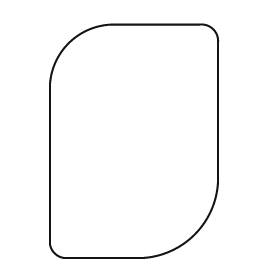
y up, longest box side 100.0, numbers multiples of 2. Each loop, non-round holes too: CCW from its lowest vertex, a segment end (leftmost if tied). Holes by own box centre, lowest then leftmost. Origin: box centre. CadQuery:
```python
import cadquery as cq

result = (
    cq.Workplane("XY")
    .moveTo(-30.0, -50.0)
    .lineTo(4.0, -50.0)
    .threePointArc((26.0, -40.0), (36.0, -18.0))
    .lineTo(36.0, 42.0)
    .threePointArc((34.0, 48.0), (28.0, 50.0))
    .lineTo(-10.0, 50.0)
    .threePointArc((-28.0, 42.0), (-36.0, 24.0))
    .lineTo(-36.0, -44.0)
    .threePointArc((-34.0, -48.0), (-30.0, -50.0))
    .close()
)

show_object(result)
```